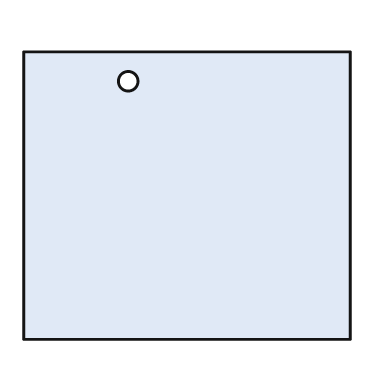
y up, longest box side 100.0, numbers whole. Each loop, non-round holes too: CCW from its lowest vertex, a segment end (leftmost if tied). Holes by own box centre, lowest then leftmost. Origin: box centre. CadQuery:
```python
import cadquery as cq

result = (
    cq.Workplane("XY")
    .moveTo(-50.0, -44.0)
    .lineTo(50.0, -44.0)
    .lineTo(50.0, 44.0)
    .lineTo(-50.0, 44.0)
    .close()
    .moveTo(-18.0, 35.0)
    .circle(3.0)
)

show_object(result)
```